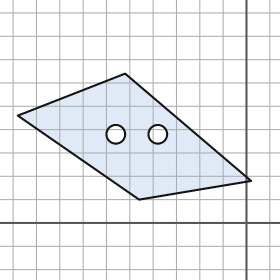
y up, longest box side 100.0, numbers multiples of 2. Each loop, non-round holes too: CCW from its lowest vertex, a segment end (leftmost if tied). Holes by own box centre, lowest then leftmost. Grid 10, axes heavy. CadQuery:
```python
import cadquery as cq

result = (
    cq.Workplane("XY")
    .moveTo(-46.0, 10.0)
    .lineTo(2.0, 18.0)
    .lineTo(-52.0, 64.0)
    .lineTo(-98.0, 46.0)
    .close()
    .moveTo(-56.0, 38.0)
    .circle(4.0)
    .moveTo(-38.0, 38.0)
    .circle(4.0)
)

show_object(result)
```